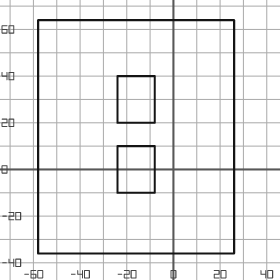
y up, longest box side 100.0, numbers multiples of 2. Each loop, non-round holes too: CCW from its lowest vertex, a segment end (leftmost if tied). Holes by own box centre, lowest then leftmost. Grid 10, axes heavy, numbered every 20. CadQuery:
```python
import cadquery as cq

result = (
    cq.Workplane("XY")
    .moveTo(-58.0, -36.0)
    .lineTo(26.0, -36.0)
    .lineTo(26.0, 64.0)
    .lineTo(-58.0, 64.0)
    .close()
    .moveTo(-24.0, -10.0)
    .lineTo(-8.0, -10.0)
    .lineTo(-8.0, 10.0)
    .lineTo(-24.0, 10.0)
    .close()
    .moveTo(-24.0, 20.0)
    .lineTo(-8.0, 20.0)
    .lineTo(-8.0, 40.0)
    .lineTo(-24.0, 40.0)
    .close()
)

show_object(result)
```